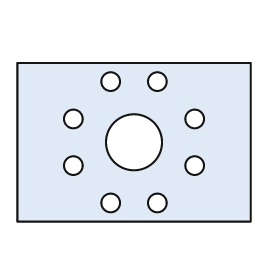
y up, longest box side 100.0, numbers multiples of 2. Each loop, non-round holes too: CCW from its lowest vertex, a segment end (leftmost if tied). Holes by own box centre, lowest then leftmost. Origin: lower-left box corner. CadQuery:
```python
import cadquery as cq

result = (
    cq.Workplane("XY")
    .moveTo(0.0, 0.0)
    .lineTo(100.0, 0.0)
    .lineTo(100.0, 68.0)
    .lineTo(0.0, 68.0)
    .close()
    .moveTo(40.0, 8.0)
    .circle(4.0)
    .moveTo(60.0, 8.0)
    .circle(4.0)
    .moveTo(24.0, 24.0)
    .circle(4.0)
    .moveTo(76.0, 24.0)
    .circle(4.0)
    .moveTo(50.0, 34.0)
    .circle(12.0)
    .moveTo(24.0, 44.0)
    .circle(4.0)
    .moveTo(76.0, 44.0)
    .circle(4.0)
    .moveTo(40.0, 60.0)
    .circle(4.0)
    .moveTo(60.0, 60.0)
    .circle(4.0)
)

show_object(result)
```